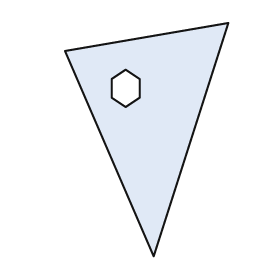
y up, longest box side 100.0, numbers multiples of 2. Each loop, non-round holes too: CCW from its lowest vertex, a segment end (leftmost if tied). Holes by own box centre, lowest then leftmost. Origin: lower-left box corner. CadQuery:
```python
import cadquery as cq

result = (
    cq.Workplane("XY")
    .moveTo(38.0, 0.0)
    .lineTo(70.0, 100.0)
    .lineTo(0.0, 88.0)
    .close()
    .moveTo(26.0, 64.0)
    .lineTo(32.0, 68.0)
    .lineTo(32.0, 76.0)
    .lineTo(26.0, 80.0)
    .lineTo(20.0, 76.0)
    .lineTo(20.0, 68.0)
    .close()
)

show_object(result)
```